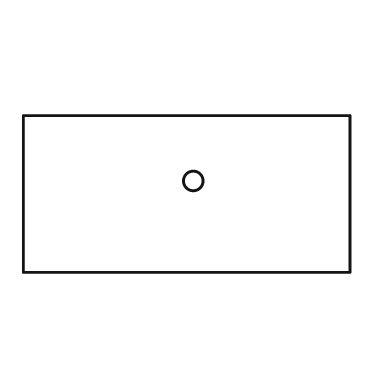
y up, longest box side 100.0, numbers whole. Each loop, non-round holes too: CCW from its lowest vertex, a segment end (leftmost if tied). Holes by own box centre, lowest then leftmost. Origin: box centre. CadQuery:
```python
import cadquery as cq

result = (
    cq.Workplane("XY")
    .moveTo(-50.0, -24.0)
    .lineTo(50.0, -24.0)
    .lineTo(50.0, 24.0)
    .lineTo(-50.0, 24.0)
    .close()
    .moveTo(2.0, 4.0)
    .circle(3.0)
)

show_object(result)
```